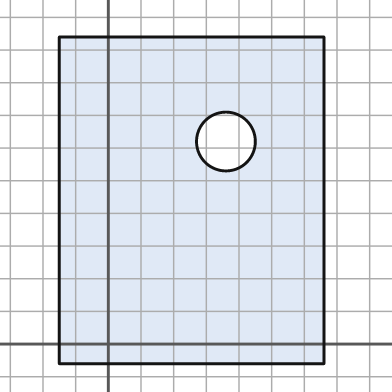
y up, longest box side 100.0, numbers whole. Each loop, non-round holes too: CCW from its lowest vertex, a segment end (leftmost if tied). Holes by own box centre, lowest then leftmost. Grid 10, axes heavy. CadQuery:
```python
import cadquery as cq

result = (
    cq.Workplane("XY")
    .moveTo(-15.0, -6.0)
    .lineTo(66.0, -6.0)
    .lineTo(66.0, 94.0)
    .lineTo(-15.0, 94.0)
    .close()
    .moveTo(36.0, 62.0)
    .circle(9.0)
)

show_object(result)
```